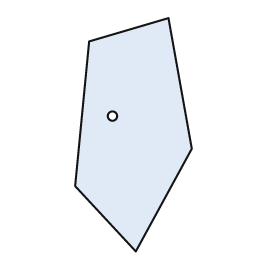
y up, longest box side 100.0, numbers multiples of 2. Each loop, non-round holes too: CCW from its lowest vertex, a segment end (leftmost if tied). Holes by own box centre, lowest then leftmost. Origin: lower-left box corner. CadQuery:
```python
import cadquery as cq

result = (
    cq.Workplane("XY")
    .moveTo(26.0, 0.0)
    .lineTo(50.0, 44.0)
    .lineTo(40.0, 100.0)
    .lineTo(6.0, 90.0)
    .lineTo(0.0, 28.0)
    .close()
    .moveTo(16.0, 58.0)
    .circle(2.0)
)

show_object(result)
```